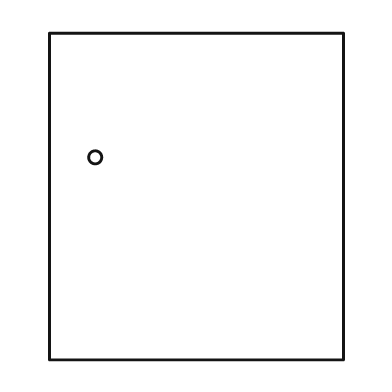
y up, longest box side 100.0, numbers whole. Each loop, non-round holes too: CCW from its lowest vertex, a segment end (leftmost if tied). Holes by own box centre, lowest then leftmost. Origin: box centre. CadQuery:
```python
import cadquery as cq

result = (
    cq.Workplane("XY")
    .moveTo(-45.0, -50.0)
    .lineTo(45.0, -50.0)
    .lineTo(45.0, 50.0)
    .lineTo(-45.0, 50.0)
    .close()
    .moveTo(-31.0, 12.0)
    .circle(2.0)
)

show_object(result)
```